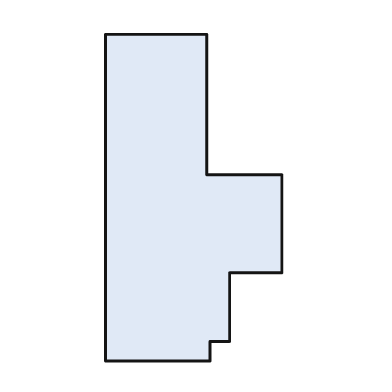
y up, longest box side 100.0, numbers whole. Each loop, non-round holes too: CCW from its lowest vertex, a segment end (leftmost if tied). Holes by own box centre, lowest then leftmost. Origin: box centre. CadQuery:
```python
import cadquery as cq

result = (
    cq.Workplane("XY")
    .moveTo(-27.0, -50.0)
    .lineTo(5.0, -50.0)
    .lineTo(5.0, -44.0)
    .lineTo(11.0, -44.0)
    .lineTo(11.0, -23.0)
    .lineTo(27.0, -23.0)
    .lineTo(27.0, 7.0)
    .lineTo(4.0, 7.0)
    .lineTo(4.0, 50.0)
    .lineTo(-27.0, 50.0)
    .close()
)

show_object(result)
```